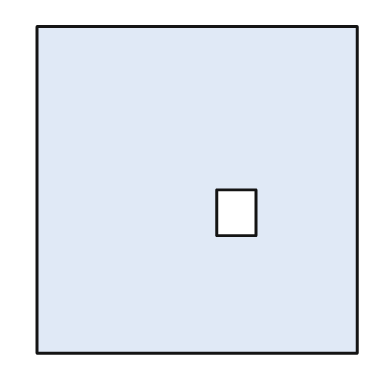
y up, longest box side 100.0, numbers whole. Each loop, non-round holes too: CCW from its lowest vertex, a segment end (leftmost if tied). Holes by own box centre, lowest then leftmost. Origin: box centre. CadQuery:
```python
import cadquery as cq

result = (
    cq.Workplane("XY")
    .moveTo(-49.0, -50.0)
    .lineTo(49.0, -50.0)
    .lineTo(49.0, 50.0)
    .lineTo(-49.0, 50.0)
    .close()
    .moveTo(6.0, -14.0)
    .lineTo(18.0, -14.0)
    .lineTo(18.0, 0.0)
    .lineTo(6.0, 0.0)
    .close()
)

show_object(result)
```